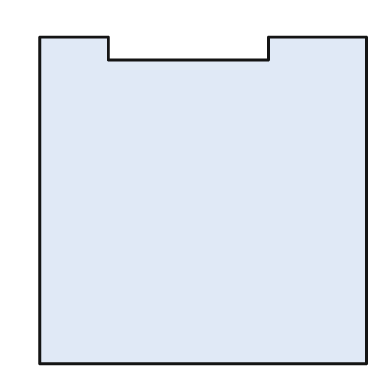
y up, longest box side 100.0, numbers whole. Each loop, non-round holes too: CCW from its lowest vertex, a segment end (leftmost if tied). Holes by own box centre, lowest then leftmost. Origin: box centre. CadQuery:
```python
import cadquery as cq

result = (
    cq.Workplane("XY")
    .moveTo(-50.0, -50.0)
    .lineTo(50.0, -50.0)
    .lineTo(50.0, 50.0)
    .lineTo(20.0, 50.0)
    .lineTo(20.0, 43.0)
    .lineTo(-29.0, 43.0)
    .lineTo(-29.0, 50.0)
    .lineTo(-50.0, 50.0)
    .close()
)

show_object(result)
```